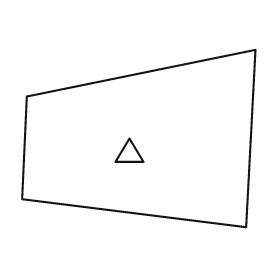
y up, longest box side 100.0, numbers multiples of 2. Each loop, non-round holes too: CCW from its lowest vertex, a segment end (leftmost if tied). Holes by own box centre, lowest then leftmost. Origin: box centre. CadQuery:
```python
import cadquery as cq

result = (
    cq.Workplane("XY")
    .moveTo(46.0, -38.0)
    .lineTo(50.0, 38.0)
    .lineTo(-48.0, 18.0)
    .lineTo(-50.0, -26.0)
    .close()
    .moveTo(-10.0, -10.0)
    .lineTo(2.0, -10.0)
    .lineTo(-4.0, 0.0)
    .close()
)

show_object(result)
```